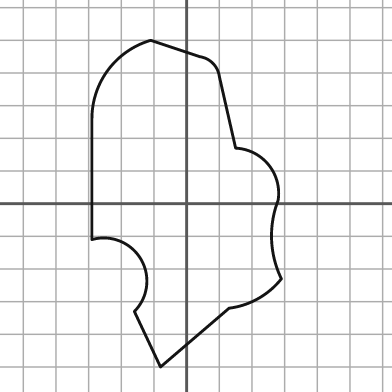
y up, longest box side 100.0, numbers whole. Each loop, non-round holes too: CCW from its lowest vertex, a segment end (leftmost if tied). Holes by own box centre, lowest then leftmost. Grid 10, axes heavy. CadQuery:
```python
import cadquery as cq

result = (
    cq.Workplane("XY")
    .moveTo(-8.0, -50.0)
    .lineTo(13.0, -32.0)
    .threePointArc((22.0, -29.0), (29.0, -23.0))
    .threePointArc((26.0, -11.0), (28.0, 1.0))
    .threePointArc((25.0, 12.0), (15.0, 17.0))
    .lineTo(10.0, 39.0)
    .threePointArc((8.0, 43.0), (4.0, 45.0))
    .lineTo(-11.0, 50.0)
    .threePointArc((-24.0, 41.0), (-29.0, 26.0))
    .lineTo(-29.0, -11.0)
    .threePointArc((-14.0, -17.0), (-16.0, -33.0))
    .close()
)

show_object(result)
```